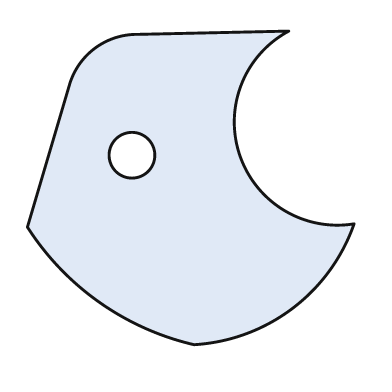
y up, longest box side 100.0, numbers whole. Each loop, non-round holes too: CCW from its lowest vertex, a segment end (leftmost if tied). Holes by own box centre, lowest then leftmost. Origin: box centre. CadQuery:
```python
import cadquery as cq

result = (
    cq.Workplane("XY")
    .moveTo(1.0, -48.0)
    .threePointArc((31.0, -37.0), (50.0, -11.0))
    .threePointArc((15.0, 10.0), (30.0, 48.0))
    .lineTo(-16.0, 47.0)
    .threePointArc((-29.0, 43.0), (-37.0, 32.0))
    .lineTo(-50.0, -12.0)
    .threePointArc((-28.0, -35.0), (1.0, -48.0))
    .close()
    .moveTo(-18.0, 10.0)
    .circle(7.0)
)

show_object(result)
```